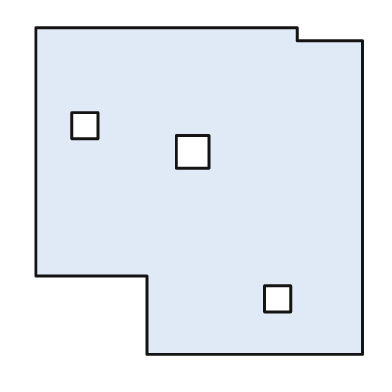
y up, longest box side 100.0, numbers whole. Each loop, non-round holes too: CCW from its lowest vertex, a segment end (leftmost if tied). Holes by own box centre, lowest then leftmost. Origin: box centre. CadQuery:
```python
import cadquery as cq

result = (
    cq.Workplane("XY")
    .moveTo(-16.0, -50.0)
    .lineTo(50.0, -50.0)
    .lineTo(50.0, 46.0)
    .lineTo(30.0, 46.0)
    .lineTo(30.0, 50.0)
    .lineTo(-50.0, 50.0)
    .lineTo(-50.0, -26.0)
    .lineTo(-16.0, -26.0)
    .close()
    .moveTo(20.0, -37.0)
    .lineTo(28.0, -37.0)
    .lineTo(28.0, -29.0)
    .lineTo(20.0, -29.0)
    .close()
    .moveTo(-7.0, 7.0)
    .lineTo(3.0, 7.0)
    .lineTo(3.0, 17.0)
    .lineTo(-7.0, 17.0)
    .close()
    .moveTo(-39.0, 16.0)
    .lineTo(-31.0, 16.0)
    .lineTo(-31.0, 24.0)
    .lineTo(-39.0, 24.0)
    .close()
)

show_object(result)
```